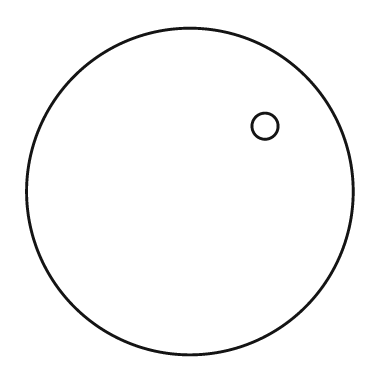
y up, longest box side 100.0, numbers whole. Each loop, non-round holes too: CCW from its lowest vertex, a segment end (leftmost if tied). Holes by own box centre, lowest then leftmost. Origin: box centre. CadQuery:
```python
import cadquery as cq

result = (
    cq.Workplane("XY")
    .moveTo(0.0, 0.0)
    .circle(50.0)
    .moveTo(23.0, 20.0)
    .circle(4.0)
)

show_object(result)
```